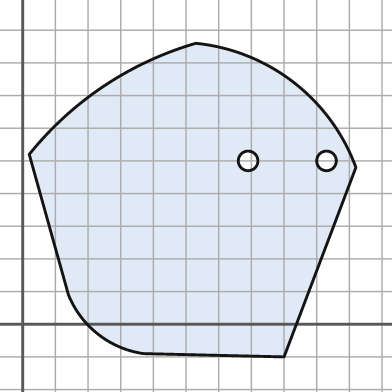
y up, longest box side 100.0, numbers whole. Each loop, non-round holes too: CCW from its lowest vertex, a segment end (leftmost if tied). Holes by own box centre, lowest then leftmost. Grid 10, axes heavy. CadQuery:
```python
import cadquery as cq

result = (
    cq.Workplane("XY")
    .moveTo(80.0, -10.0)
    .lineTo(102.0, 48.0)
    .threePointArc((83.0, 74.0), (53.0, 86.0))
    .threePointArc((25.0, 73.0), (2.0, 52.0))
    .lineTo(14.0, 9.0)
    .threePointArc((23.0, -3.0), (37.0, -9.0))
    .close()
    .moveTo(69.0, 50.0)
    .circle(3.0)
    .moveTo(93.0, 50.0)
    .circle(3.0)
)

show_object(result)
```